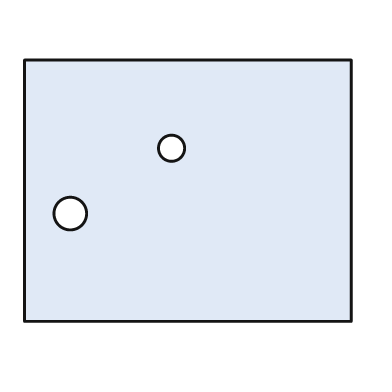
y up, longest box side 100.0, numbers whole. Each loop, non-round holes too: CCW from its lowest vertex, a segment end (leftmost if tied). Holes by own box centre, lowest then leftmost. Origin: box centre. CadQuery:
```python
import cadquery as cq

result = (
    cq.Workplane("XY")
    .moveTo(-50.0, -40.0)
    .lineTo(50.0, -40.0)
    .lineTo(50.0, 40.0)
    .lineTo(-50.0, 40.0)
    .close()
    .moveTo(-36.0, -7.0)
    .circle(5.0)
    .moveTo(-5.0, 13.0)
    .circle(4.0)
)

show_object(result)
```